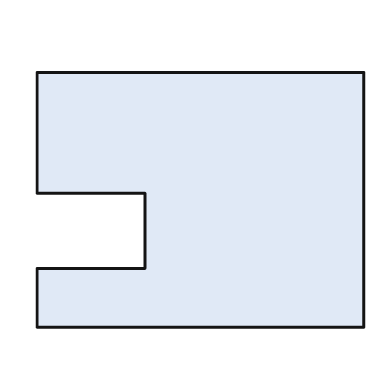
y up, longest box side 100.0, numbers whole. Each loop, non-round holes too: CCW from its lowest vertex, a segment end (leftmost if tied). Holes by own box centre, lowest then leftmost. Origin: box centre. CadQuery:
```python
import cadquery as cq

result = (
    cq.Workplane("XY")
    .moveTo(-50.0, -39.0)
    .lineTo(50.0, -39.0)
    .lineTo(50.0, 39.0)
    .lineTo(-50.0, 39.0)
    .lineTo(-50.0, 2.0)
    .lineTo(-17.0, 2.0)
    .lineTo(-17.0, -21.0)
    .lineTo(-50.0, -21.0)
    .close()
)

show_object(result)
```